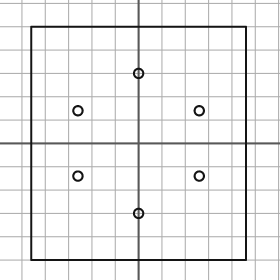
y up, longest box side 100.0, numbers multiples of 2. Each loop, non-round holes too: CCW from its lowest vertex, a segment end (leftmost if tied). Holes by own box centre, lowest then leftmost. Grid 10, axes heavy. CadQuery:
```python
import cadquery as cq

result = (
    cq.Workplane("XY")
    .moveTo(-46.0, -50.0)
    .lineTo(46.0, -50.0)
    .lineTo(46.0, 50.0)
    .lineTo(-46.0, 50.0)
    .close()
    .moveTo(0.0, -30.0)
    .circle(2.0)
    .moveTo(-26.0, -14.0)
    .circle(2.0)
    .moveTo(26.0, -14.0)
    .circle(2.0)
    .moveTo(-26.0, 14.0)
    .circle(2.0)
    .moveTo(26.0, 14.0)
    .circle(2.0)
    .moveTo(0.0, 30.0)
    .circle(2.0)
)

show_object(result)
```